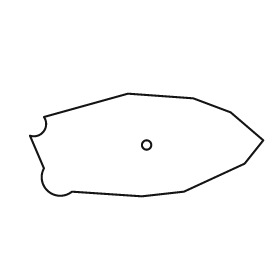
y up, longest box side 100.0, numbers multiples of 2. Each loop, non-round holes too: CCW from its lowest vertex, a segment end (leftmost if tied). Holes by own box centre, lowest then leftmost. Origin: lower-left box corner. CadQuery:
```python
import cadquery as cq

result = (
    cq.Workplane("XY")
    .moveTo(48.0, 0.0)
    .lineTo(66.0, 2.0)
    .lineTo(92.0, 14.0)
    .lineTo(100.0, 24.0)
    .lineTo(86.0, 36.0)
    .lineTo(70.0, 42.0)
    .lineTo(42.0, 44.0)
    .lineTo(6.0, 34.0)
    .threePointArc((6.0, 28.0), (0.0, 26.0))
    .lineTo(6.0, 12.0)
    .threePointArc((8.0, 2.0), (18.0, 2.0))
    .close()
    .moveTo(50.0, 22.0)
    .circle(2.0)
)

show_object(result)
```